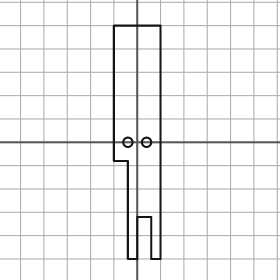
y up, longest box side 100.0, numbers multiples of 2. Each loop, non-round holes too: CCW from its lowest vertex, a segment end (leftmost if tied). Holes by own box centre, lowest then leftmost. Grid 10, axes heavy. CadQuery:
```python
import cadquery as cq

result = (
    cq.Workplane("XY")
    .moveTo(-4.0, -50.0)
    .lineTo(0.0, -50.0)
    .lineTo(0.0, -32.0)
    .lineTo(6.0, -32.0)
    .lineTo(6.0, -50.0)
    .lineTo(10.0, -50.0)
    .lineTo(10.0, 50.0)
    .lineTo(-10.0, 50.0)
    .lineTo(-10.0, -8.0)
    .lineTo(-4.0, -8.0)
    .close()
    .moveTo(-4.0, 0.0)
    .circle(2.0)
    .moveTo(4.0, 0.0)
    .circle(2.0)
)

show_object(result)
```